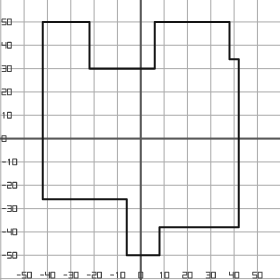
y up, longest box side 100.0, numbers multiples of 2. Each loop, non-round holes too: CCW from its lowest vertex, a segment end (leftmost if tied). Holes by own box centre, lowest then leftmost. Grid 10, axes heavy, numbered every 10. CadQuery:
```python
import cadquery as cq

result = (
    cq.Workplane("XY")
    .moveTo(-6.0, -50.0)
    .lineTo(8.0, -50.0)
    .lineTo(8.0, -38.0)
    .lineTo(42.0, -38.0)
    .lineTo(42.0, 34.0)
    .lineTo(38.0, 34.0)
    .lineTo(38.0, 50.0)
    .lineTo(6.0, 50.0)
    .lineTo(6.0, 30.0)
    .lineTo(-22.0, 30.0)
    .lineTo(-22.0, 50.0)
    .lineTo(-42.0, 50.0)
    .lineTo(-42.0, -26.0)
    .lineTo(-6.0, -26.0)
    .close()
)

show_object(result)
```